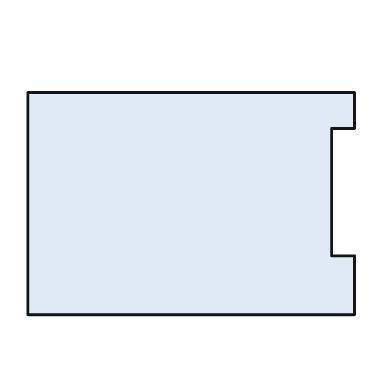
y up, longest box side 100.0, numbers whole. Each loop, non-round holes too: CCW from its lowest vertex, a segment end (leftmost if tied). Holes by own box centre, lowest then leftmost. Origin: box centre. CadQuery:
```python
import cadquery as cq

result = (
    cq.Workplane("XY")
    .moveTo(-50.0, -34.0)
    .lineTo(50.0, -34.0)
    .lineTo(50.0, -16.0)
    .lineTo(43.0, -16.0)
    .lineTo(43.0, 23.0)
    .lineTo(50.0, 23.0)
    .lineTo(50.0, 34.0)
    .lineTo(-50.0, 34.0)
    .close()
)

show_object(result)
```